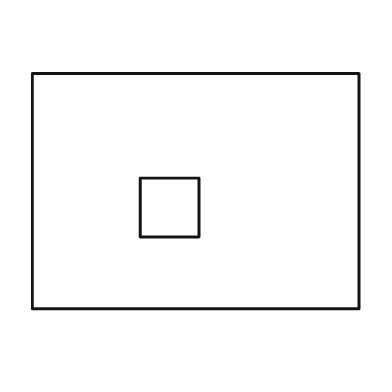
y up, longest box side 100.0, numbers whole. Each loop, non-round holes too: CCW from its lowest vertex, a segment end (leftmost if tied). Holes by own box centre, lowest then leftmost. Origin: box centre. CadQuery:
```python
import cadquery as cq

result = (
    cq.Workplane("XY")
    .moveTo(-50.0, -36.0)
    .lineTo(50.0, -36.0)
    .lineTo(50.0, 36.0)
    .lineTo(-50.0, 36.0)
    .close()
    .moveTo(-17.0, -14.0)
    .lineTo(1.0, -14.0)
    .lineTo(1.0, 4.0)
    .lineTo(-17.0, 4.0)
    .close()
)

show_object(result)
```